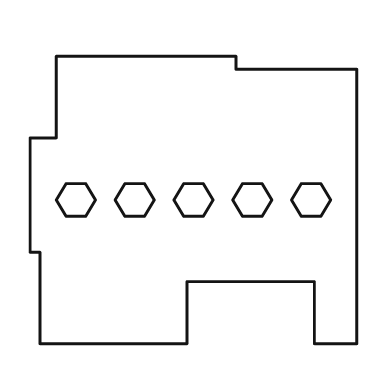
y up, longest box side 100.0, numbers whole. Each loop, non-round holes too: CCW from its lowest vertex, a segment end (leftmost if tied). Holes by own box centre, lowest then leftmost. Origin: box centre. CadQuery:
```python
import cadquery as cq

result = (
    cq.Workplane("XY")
    .moveTo(-47.0, -44.0)
    .lineTo(-2.0, -44.0)
    .lineTo(-2.0, -25.0)
    .lineTo(37.0, -25.0)
    .lineTo(37.0, -44.0)
    .lineTo(50.0, -44.0)
    .lineTo(50.0, 40.0)
    .lineTo(13.0, 40.0)
    .lineTo(13.0, 44.0)
    .lineTo(-42.0, 44.0)
    .lineTo(-42.0, 19.0)
    .lineTo(-50.0, 19.0)
    .lineTo(-50.0, -16.0)
    .lineTo(-47.0, -16.0)
    .close()
    .moveTo(-39.0, -5.0)
    .lineTo(-33.0, -5.0)
    .lineTo(-30.0, 0.0)
    .lineTo(-33.0, 5.0)
    .lineTo(-39.0, 5.0)
    .lineTo(-42.0, 0.0)
    .close()
    .moveTo(-21.0, -5.0)
    .lineTo(-15.0, -5.0)
    .lineTo(-12.0, 0.0)
    .lineTo(-15.0, 5.0)
    .lineTo(-21.0, 5.0)
    .lineTo(-24.0, 0.0)
    .close()
    .moveTo(-3.0, -5.0)
    .lineTo(3.0, -5.0)
    .lineTo(6.0, 0.0)
    .lineTo(3.0, 5.0)
    .lineTo(-3.0, 5.0)
    .lineTo(-6.0, 0.0)
    .close()
    .moveTo(15.0, -5.0)
    .lineTo(21.0, -5.0)
    .lineTo(24.0, 0.0)
    .lineTo(21.0, 5.0)
    .lineTo(15.0, 5.0)
    .lineTo(12.0, 0.0)
    .close()
    .moveTo(33.0, -5.0)
    .lineTo(39.0, -5.0)
    .lineTo(42.0, 0.0)
    .lineTo(39.0, 5.0)
    .lineTo(33.0, 5.0)
    .lineTo(30.0, 0.0)
    .close()
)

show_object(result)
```